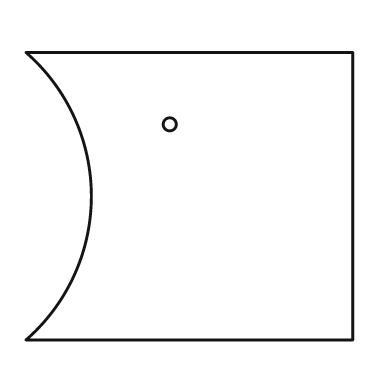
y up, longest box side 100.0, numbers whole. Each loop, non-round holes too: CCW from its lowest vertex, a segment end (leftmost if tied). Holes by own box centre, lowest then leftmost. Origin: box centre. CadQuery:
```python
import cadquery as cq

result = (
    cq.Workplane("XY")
    .moveTo(-50.0, -44.0)
    .lineTo(50.0, -44.0)
    .lineTo(50.0, 44.0)
    .lineTo(-50.0, 44.0)
    .threePointArc((-30.0, 0.0), (-50.0, -44.0))
    .close()
    .moveTo(-6.0, 22.0)
    .circle(2.0)
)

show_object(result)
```